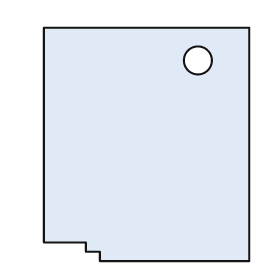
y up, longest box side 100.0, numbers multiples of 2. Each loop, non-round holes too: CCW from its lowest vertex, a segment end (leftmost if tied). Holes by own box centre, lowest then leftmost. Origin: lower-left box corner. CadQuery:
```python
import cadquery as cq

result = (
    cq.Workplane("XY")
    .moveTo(24.0, 0.0)
    .lineTo(88.0, 0.0)
    .lineTo(88.0, 100.0)
    .lineTo(0.0, 100.0)
    .lineTo(0.0, 8.0)
    .lineTo(18.0, 8.0)
    .lineTo(18.0, 4.0)
    .lineTo(24.0, 4.0)
    .close()
    .moveTo(66.0, 86.0)
    .circle(6.0)
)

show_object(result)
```